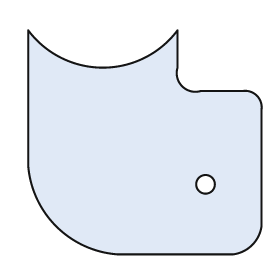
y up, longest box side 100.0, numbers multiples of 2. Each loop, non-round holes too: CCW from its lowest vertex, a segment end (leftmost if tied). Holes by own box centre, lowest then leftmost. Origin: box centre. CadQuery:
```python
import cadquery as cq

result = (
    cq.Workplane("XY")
    .moveTo(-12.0, -48.0)
    .lineTo(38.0, -48.0)
    .threePointArc((46.0, -44.0), (50.0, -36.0))
    .lineTo(50.0, 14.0)
    .threePointArc((48.0, 20.0), (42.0, 22.0))
    .lineTo(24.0, 22.0)
    .threePointArc((16.0, 24.0), (14.0, 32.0))
    .lineTo(14.0, 48.0)
    .threePointArc((-18.0, 32.0), (-50.0, 48.0))
    .lineTo(-50.0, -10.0)
    .threePointArc((-38.0, -36.0), (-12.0, -48.0))
    .close()
    .moveTo(26.0, -18.0)
    .circle(4.0)
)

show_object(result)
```